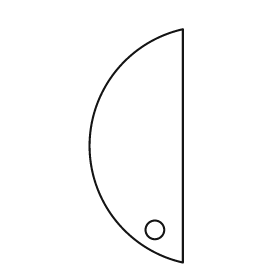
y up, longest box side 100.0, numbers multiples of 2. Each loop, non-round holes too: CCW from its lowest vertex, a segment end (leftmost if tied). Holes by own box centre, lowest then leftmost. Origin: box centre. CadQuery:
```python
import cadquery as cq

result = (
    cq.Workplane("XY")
    .moveTo(20.0, -50.0)
    .lineTo(20.0, 50.0)
    .threePointArc((-20.0, 0.0), (20.0, -50.0))
    .close()
    .moveTo(8.0, -36.0)
    .circle(4.0)
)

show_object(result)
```